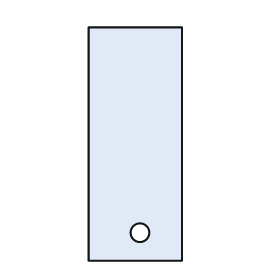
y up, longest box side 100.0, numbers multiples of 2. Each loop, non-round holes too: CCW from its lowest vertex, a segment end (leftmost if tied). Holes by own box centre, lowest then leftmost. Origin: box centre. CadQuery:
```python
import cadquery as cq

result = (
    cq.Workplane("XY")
    .moveTo(-20.0, -50.0)
    .lineTo(20.0, -50.0)
    .lineTo(20.0, 50.0)
    .lineTo(-20.0, 50.0)
    .close()
    .moveTo(2.0, -38.0)
    .circle(4.0)
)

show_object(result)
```